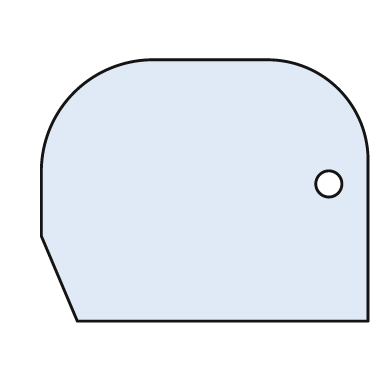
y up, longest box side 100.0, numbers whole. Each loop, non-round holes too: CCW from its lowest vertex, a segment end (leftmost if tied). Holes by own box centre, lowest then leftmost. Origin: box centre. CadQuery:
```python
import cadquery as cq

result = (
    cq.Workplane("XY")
    .moveTo(-39.0, -40.0)
    .lineTo(50.0, -40.0)
    .lineTo(50.0, 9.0)
    .threePointArc((41.0, 31.0), (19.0, 40.0))
    .lineTo(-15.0, 40.0)
    .threePointArc((-40.0, 30.0), (-50.0, 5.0))
    .lineTo(-50.0, -14.0)
    .close()
    .moveTo(38.0, 2.0)
    .circle(4.0)
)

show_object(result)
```